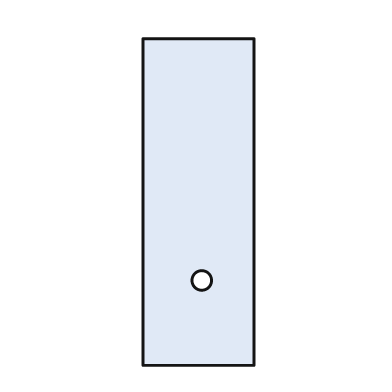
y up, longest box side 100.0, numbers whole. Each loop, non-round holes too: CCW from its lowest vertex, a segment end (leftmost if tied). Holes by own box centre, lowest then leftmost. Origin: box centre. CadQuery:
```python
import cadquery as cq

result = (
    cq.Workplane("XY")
    .moveTo(-17.0, -50.0)
    .lineTo(17.0, -50.0)
    .lineTo(17.0, 50.0)
    .lineTo(-17.0, 50.0)
    .close()
    .moveTo(1.0, -24.0)
    .circle(3.0)
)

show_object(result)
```